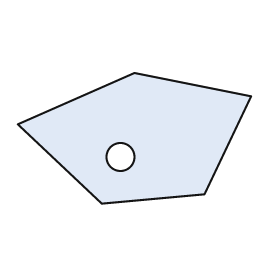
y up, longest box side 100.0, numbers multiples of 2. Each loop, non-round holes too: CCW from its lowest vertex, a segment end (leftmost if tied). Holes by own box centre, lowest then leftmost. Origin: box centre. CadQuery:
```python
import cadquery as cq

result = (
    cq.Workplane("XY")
    .moveTo(-14.0, -28.0)
    .lineTo(30.0, -24.0)
    .lineTo(50.0, 18.0)
    .lineTo(0.0, 28.0)
    .lineTo(-50.0, 6.0)
    .close()
    .moveTo(-6.0, -8.0)
    .circle(6.0)
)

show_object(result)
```